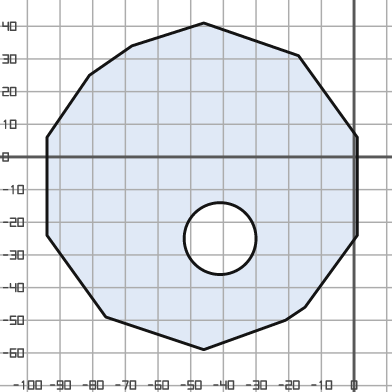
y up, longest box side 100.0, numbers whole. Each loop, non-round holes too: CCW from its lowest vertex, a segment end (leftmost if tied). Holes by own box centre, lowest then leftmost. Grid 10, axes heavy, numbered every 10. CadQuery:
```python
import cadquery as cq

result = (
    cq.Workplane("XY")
    .moveTo(-46.0, -59.0)
    .lineTo(-21.0, -50.0)
    .lineTo(-15.0, -46.0)
    .lineTo(1.0, -24.0)
    .lineTo(1.0, 6.0)
    .lineTo(-17.0, 31.0)
    .lineTo(-46.0, 41.0)
    .lineTo(-68.0, 34.0)
    .lineTo(-81.0, 25.0)
    .lineTo(-94.0, 6.0)
    .lineTo(-94.0, -24.0)
    .lineTo(-76.0, -49.0)
    .close()
    .moveTo(-41.0, -25.0)
    .circle(11.0)
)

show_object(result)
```